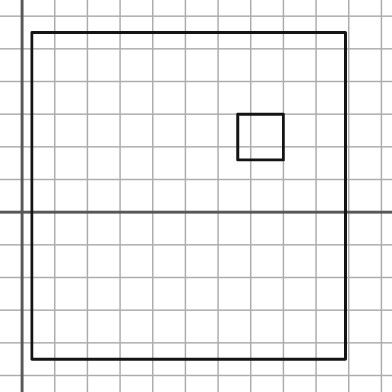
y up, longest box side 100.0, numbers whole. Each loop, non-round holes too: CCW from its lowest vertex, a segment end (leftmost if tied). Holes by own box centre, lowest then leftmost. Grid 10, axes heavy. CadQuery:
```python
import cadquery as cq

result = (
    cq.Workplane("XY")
    .moveTo(3.0, -45.0)
    .lineTo(99.0, -45.0)
    .lineTo(99.0, 55.0)
    .lineTo(3.0, 55.0)
    .close()
    .moveTo(66.0, 16.0)
    .lineTo(80.0, 16.0)
    .lineTo(80.0, 30.0)
    .lineTo(66.0, 30.0)
    .close()
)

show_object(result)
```